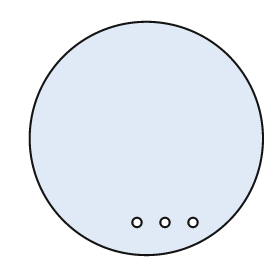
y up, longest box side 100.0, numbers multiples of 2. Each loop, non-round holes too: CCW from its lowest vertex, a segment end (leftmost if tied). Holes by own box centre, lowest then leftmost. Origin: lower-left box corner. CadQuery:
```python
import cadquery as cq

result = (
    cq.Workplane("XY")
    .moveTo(50.0, 50.0)
    .circle(50.0)
    .moveTo(46.0, 14.0)
    .circle(2.0)
    .moveTo(58.0, 14.0)
    .circle(2.0)
    .moveTo(70.0, 14.0)
    .circle(2.0)
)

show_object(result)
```